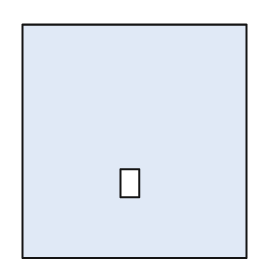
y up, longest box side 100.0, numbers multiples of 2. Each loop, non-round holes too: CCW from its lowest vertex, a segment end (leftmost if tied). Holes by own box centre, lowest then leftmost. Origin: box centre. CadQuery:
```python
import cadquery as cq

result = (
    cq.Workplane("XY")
    .moveTo(-48.0, -50.0)
    .lineTo(48.0, -50.0)
    .lineTo(48.0, 50.0)
    .lineTo(-48.0, 50.0)
    .close()
    .moveTo(-6.0, -24.0)
    .lineTo(2.0, -24.0)
    .lineTo(2.0, -12.0)
    .lineTo(-6.0, -12.0)
    .close()
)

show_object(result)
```